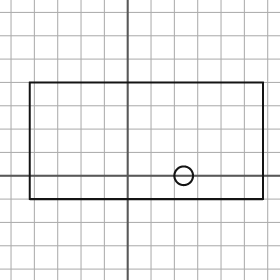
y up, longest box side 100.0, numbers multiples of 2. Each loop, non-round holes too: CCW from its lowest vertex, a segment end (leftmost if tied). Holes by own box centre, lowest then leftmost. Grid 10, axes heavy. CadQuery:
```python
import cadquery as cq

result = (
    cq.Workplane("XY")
    .moveTo(-42.0, -10.0)
    .lineTo(58.0, -10.0)
    .lineTo(58.0, 40.0)
    .lineTo(-42.0, 40.0)
    .close()
    .moveTo(24.0, 0.0)
    .circle(4.0)
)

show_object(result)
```